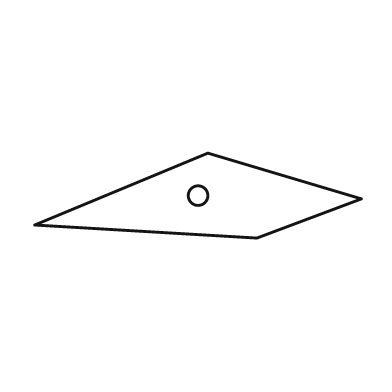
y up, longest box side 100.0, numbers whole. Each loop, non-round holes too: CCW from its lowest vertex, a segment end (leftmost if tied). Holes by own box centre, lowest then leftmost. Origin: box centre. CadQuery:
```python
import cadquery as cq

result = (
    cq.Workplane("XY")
    .moveTo(18.0, -13.0)
    .lineTo(50.0, -1.0)
    .lineTo(3.0, 13.0)
    .lineTo(-50.0, -9.0)
    .close()
    .moveTo(0.0, 0.0)
    .circle(3.0)
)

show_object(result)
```